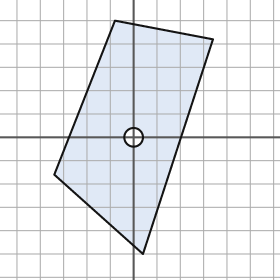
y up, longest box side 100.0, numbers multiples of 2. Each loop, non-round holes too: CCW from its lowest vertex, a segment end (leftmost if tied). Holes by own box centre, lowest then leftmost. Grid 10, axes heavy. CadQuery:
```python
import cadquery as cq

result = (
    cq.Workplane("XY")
    .moveTo(4.0, -50.0)
    .lineTo(34.0, 42.0)
    .lineTo(-8.0, 50.0)
    .lineTo(-34.0, -16.0)
    .close()
    .moveTo(0.0, 0.0)
    .circle(4.0)
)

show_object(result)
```